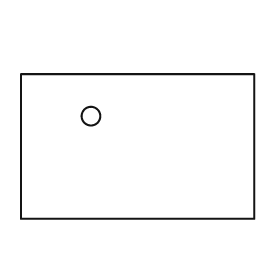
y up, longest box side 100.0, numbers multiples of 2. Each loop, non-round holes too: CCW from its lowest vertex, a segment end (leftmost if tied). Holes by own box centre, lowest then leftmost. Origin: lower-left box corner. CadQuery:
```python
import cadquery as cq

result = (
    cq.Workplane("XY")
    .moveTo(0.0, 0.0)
    .lineTo(100.0, 0.0)
    .lineTo(100.0, 62.0)
    .lineTo(0.0, 62.0)
    .close()
    .moveTo(30.0, 44.0)
    .circle(4.0)
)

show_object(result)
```